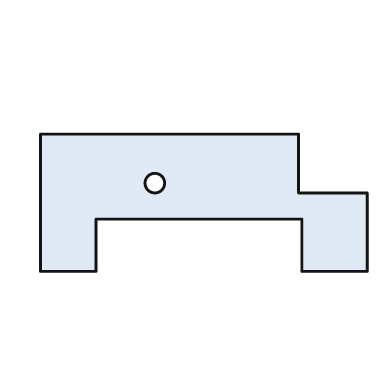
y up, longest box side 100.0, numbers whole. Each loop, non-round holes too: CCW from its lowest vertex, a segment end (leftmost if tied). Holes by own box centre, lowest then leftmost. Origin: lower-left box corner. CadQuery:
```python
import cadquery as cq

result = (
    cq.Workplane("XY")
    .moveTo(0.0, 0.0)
    .lineTo(17.0, 0.0)
    .lineTo(17.0, 16.0)
    .lineTo(80.0, 16.0)
    .lineTo(80.0, 0.0)
    .lineTo(100.0, 0.0)
    .lineTo(100.0, 24.0)
    .lineTo(79.0, 24.0)
    .lineTo(79.0, 42.0)
    .lineTo(0.0, 42.0)
    .close()
    .moveTo(35.0, 27.0)
    .circle(3.0)
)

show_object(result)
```